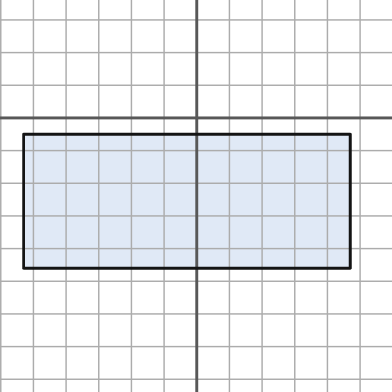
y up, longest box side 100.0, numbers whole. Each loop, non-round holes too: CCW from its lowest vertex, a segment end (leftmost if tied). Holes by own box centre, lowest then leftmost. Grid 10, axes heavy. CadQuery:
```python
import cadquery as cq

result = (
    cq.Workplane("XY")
    .moveTo(-53.0, -46.0)
    .lineTo(47.0, -46.0)
    .lineTo(47.0, -5.0)
    .lineTo(-53.0, -5.0)
    .close()
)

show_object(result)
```